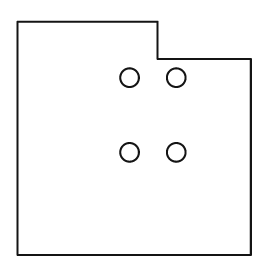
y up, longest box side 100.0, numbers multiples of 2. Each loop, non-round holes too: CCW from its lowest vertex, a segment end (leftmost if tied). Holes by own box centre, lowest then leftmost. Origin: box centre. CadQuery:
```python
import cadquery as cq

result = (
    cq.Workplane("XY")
    .moveTo(-50.0, -50.0)
    .lineTo(50.0, -50.0)
    .lineTo(50.0, 34.0)
    .lineTo(10.0, 34.0)
    .lineTo(10.0, 50.0)
    .lineTo(-50.0, 50.0)
    .close()
    .moveTo(-2.0, -6.0)
    .circle(4.0)
    .moveTo(18.0, -6.0)
    .circle(4.0)
    .moveTo(-2.0, 26.0)
    .circle(4.0)
    .moveTo(18.0, 26.0)
    .circle(4.0)
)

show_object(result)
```